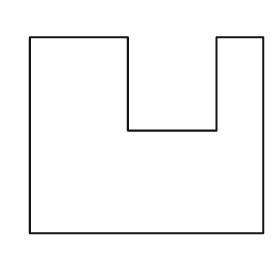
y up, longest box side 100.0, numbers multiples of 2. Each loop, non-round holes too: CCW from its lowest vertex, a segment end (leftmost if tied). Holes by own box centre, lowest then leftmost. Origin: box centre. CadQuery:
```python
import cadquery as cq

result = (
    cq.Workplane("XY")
    .moveTo(-50.0, -42.0)
    .lineTo(50.0, -42.0)
    .lineTo(50.0, 42.0)
    .lineTo(30.0, 42.0)
    .lineTo(30.0, 2.0)
    .lineTo(-8.0, 2.0)
    .lineTo(-8.0, 42.0)
    .lineTo(-50.0, 42.0)
    .close()
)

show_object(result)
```